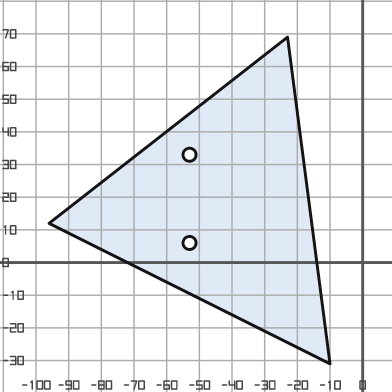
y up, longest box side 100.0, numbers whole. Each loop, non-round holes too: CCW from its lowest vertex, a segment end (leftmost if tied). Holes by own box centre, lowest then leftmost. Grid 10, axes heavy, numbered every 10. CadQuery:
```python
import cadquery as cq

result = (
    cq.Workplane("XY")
    .moveTo(-10.0, -31.0)
    .lineTo(-23.0, 69.0)
    .lineTo(-96.0, 12.0)
    .close()
    .moveTo(-53.0, 6.0)
    .circle(2.0)
    .moveTo(-53.0, 33.0)
    .circle(2.0)
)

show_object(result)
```